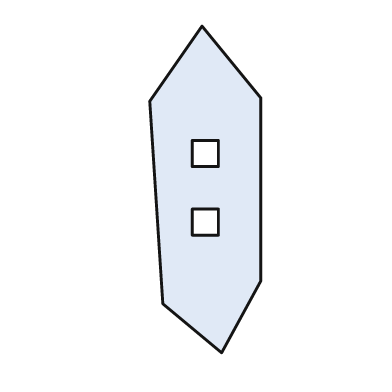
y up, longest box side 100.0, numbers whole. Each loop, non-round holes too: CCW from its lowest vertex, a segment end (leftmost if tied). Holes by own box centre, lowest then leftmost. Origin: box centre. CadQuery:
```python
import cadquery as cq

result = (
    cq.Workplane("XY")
    .moveTo(5.0, -50.0)
    .lineTo(17.0, -28.0)
    .lineTo(17.0, 28.0)
    .lineTo(-1.0, 50.0)
    .lineTo(-17.0, 27.0)
    .lineTo(-13.0, -35.0)
    .close()
    .moveTo(-4.0, -14.0)
    .lineTo(4.0, -14.0)
    .lineTo(4.0, -6.0)
    .lineTo(-4.0, -6.0)
    .close()
    .moveTo(-4.0, 7.0)
    .lineTo(4.0, 7.0)
    .lineTo(4.0, 15.0)
    .lineTo(-4.0, 15.0)
    .close()
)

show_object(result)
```